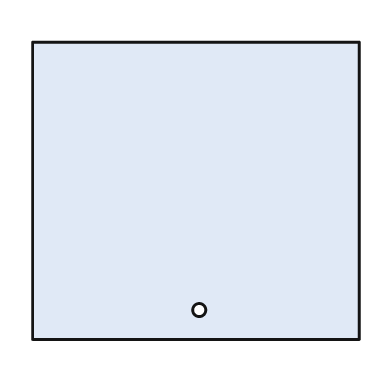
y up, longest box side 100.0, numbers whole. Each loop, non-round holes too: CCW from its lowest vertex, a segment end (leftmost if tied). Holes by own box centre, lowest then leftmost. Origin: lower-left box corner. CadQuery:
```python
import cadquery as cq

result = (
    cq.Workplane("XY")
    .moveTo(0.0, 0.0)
    .lineTo(100.0, 0.0)
    .lineTo(100.0, 91.0)
    .lineTo(0.0, 91.0)
    .close()
    .moveTo(51.0, 9.0)
    .circle(2.0)
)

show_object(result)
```